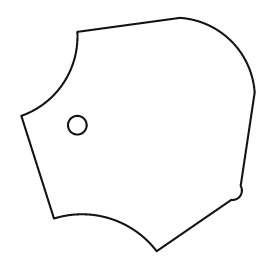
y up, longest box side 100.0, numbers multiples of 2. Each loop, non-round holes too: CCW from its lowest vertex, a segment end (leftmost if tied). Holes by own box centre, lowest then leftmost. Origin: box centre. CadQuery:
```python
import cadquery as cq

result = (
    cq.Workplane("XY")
    .moveTo(8.0, -50.0)
    .lineTo(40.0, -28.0)
    .threePointArc((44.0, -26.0), (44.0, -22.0))
    .lineTo(50.0, 18.0)
    .threePointArc((40.0, 40.0), (18.0, 50.0))
    .lineTo(-26.0, 44.0)
    .threePointArc((-32.0, 22.0), (-50.0, 8.0))
    .lineTo(-36.0, -36.0)
    .threePointArc((-12.0, -36.0), (8.0, -50.0))
    .close()
    .moveTo(-26.0, 4.0)
    .circle(4.0)
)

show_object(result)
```